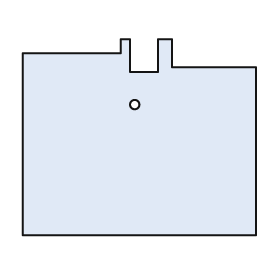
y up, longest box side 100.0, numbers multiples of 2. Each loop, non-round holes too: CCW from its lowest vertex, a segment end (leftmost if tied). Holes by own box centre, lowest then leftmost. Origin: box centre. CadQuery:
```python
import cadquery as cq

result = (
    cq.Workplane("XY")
    .moveTo(-50.0, -42.0)
    .lineTo(50.0, -42.0)
    .lineTo(50.0, 30.0)
    .lineTo(14.0, 30.0)
    .lineTo(14.0, 42.0)
    .lineTo(8.0, 42.0)
    .lineTo(8.0, 28.0)
    .lineTo(-4.0, 28.0)
    .lineTo(-4.0, 42.0)
    .lineTo(-8.0, 42.0)
    .lineTo(-8.0, 36.0)
    .lineTo(-50.0, 36.0)
    .close()
    .moveTo(-2.0, 14.0)
    .circle(2.0)
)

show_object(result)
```